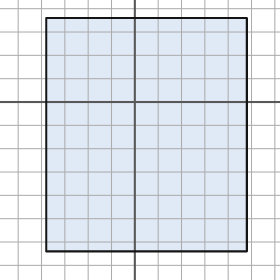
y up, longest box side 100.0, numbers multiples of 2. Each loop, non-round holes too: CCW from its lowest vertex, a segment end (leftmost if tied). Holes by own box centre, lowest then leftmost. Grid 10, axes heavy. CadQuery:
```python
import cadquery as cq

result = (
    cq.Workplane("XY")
    .moveTo(-38.0, -64.0)
    .lineTo(48.0, -64.0)
    .lineTo(48.0, 36.0)
    .lineTo(-38.0, 36.0)
    .close()
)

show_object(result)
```